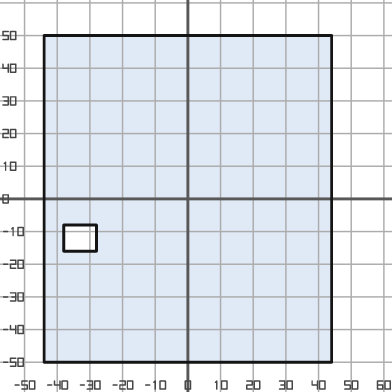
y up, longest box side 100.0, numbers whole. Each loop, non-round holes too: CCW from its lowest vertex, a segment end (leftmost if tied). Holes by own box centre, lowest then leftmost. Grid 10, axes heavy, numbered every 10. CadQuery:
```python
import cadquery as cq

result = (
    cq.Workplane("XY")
    .moveTo(-44.0, -50.0)
    .lineTo(44.0, -50.0)
    .lineTo(44.0, 50.0)
    .lineTo(-44.0, 50.0)
    .close()
    .moveTo(-38.0, -16.0)
    .lineTo(-28.0, -16.0)
    .lineTo(-28.0, -8.0)
    .lineTo(-38.0, -8.0)
    .close()
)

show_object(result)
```